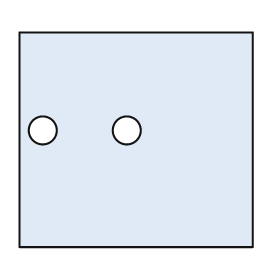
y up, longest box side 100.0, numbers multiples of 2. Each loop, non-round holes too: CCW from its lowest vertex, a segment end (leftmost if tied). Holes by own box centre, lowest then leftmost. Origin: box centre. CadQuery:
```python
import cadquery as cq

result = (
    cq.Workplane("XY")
    .moveTo(-50.0, -46.0)
    .lineTo(50.0, -46.0)
    .lineTo(50.0, 46.0)
    .lineTo(-50.0, 46.0)
    .close()
    .moveTo(-40.0, 4.0)
    .circle(6.0)
    .moveTo(-4.0, 4.0)
    .circle(6.0)
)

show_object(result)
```